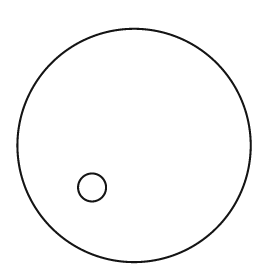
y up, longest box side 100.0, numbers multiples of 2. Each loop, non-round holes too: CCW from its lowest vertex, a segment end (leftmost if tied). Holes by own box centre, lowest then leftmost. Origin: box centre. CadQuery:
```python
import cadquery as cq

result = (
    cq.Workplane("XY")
    .moveTo(0.0, 0.0)
    .circle(50.0)
    .moveTo(-18.0, -18.0)
    .circle(6.0)
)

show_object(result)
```